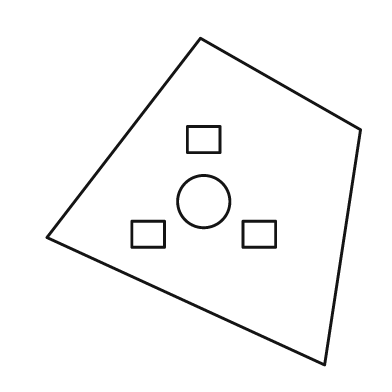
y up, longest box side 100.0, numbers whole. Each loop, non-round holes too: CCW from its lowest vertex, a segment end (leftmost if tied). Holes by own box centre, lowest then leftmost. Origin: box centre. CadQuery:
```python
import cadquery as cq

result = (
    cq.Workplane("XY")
    .moveTo(37.0, -50.0)
    .lineTo(48.0, 22.0)
    .lineTo(-1.0, 50.0)
    .lineTo(-48.0, -11.0)
    .close()
    .moveTo(-22.0, -14.0)
    .lineTo(-12.0, -14.0)
    .lineTo(-12.0, -6.0)
    .lineTo(-22.0, -6.0)
    .close()
    .moveTo(12.0, -14.0)
    .lineTo(22.0, -14.0)
    .lineTo(22.0, -6.0)
    .lineTo(12.0, -6.0)
    .close()
    .moveTo(0.0, 0.0)
    .circle(8.0)
    .moveTo(-5.0, 15.0)
    .lineTo(5.0, 15.0)
    .lineTo(5.0, 23.0)
    .lineTo(-5.0, 23.0)
    .close()
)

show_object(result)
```